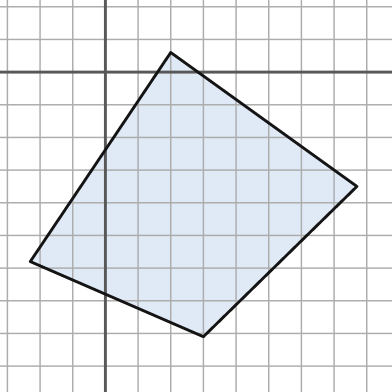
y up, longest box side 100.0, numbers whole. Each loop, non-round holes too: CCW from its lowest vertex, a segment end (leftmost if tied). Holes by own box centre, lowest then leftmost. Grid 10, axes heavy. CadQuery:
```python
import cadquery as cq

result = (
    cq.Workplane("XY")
    .moveTo(30.0, -81.0)
    .lineTo(77.0, -35.0)
    .lineTo(20.0, 6.0)
    .lineTo(-23.0, -58.0)
    .close()
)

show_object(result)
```